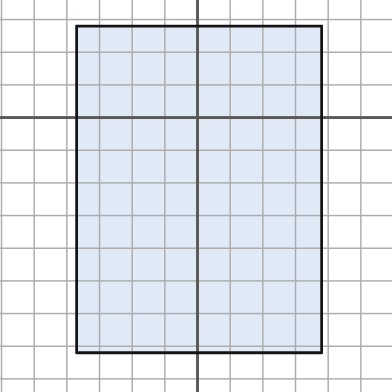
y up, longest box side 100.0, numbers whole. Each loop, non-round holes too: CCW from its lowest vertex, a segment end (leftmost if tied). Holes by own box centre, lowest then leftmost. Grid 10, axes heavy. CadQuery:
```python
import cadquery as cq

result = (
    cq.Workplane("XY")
    .moveTo(-37.0, -72.0)
    .lineTo(38.0, -72.0)
    .lineTo(38.0, 28.0)
    .lineTo(-37.0, 28.0)
    .close()
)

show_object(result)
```